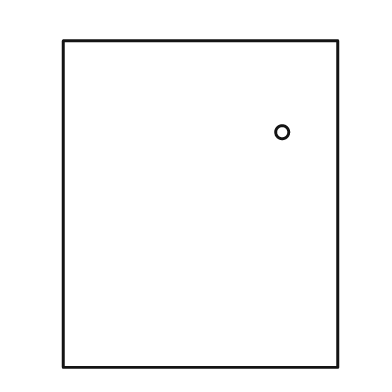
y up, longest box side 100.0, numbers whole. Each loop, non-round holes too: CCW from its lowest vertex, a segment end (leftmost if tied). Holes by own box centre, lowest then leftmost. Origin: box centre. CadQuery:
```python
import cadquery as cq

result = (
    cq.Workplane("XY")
    .moveTo(-42.0, -50.0)
    .lineTo(42.0, -50.0)
    .lineTo(42.0, 50.0)
    .lineTo(-42.0, 50.0)
    .close()
    .moveTo(25.0, 22.0)
    .circle(2.0)
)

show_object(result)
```